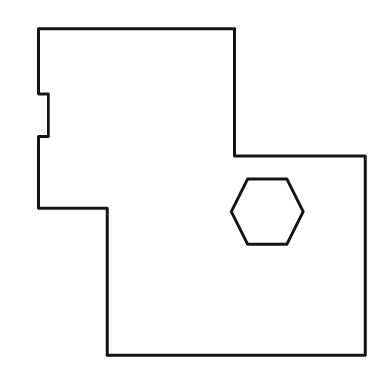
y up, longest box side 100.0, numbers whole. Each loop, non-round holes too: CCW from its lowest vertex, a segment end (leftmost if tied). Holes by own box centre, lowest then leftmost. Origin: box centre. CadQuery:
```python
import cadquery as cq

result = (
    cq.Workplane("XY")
    .moveTo(-29.0, -50.0)
    .lineTo(50.0, -50.0)
    .lineTo(50.0, 11.0)
    .lineTo(10.0, 11.0)
    .lineTo(10.0, 50.0)
    .lineTo(-50.0, 50.0)
    .lineTo(-50.0, 30.0)
    .lineTo(-47.0, 30.0)
    .lineTo(-47.0, 17.0)
    .lineTo(-50.0, 17.0)
    .lineTo(-50.0, -5.0)
    .lineTo(-29.0, -5.0)
    .close()
    .moveTo(14.0, -16.0)
    .lineTo(26.0, -16.0)
    .lineTo(31.0, -6.0)
    .lineTo(26.0, 4.0)
    .lineTo(14.0, 4.0)
    .lineTo(9.0, -6.0)
    .close()
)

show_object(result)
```